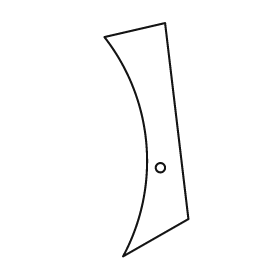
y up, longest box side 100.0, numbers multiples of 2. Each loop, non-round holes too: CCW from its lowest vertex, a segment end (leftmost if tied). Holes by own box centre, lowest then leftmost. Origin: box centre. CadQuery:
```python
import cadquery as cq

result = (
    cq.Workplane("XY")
    .moveTo(-10.0, -50.0)
    .lineTo(18.0, -34.0)
    .lineTo(8.0, 50.0)
    .lineTo(-18.0, 44.0)
    .threePointArc((0.0, -2.0), (-10.0, -50.0))
    .close()
    .moveTo(6.0, -12.0)
    .circle(2.0)
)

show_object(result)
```